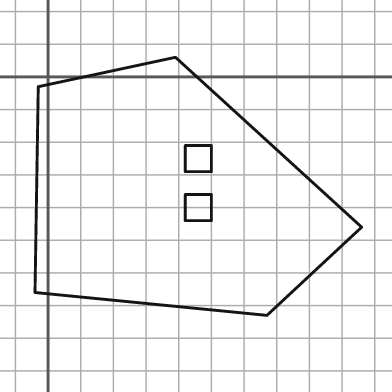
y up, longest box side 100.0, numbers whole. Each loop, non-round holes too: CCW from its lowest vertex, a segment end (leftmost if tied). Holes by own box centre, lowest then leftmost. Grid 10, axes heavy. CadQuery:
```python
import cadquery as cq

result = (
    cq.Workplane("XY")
    .moveTo(67.0, -73.0)
    .lineTo(96.0, -46.0)
    .lineTo(39.0, 6.0)
    .lineTo(-3.0, -3.0)
    .lineTo(-4.0, -66.0)
    .close()
    .moveTo(42.0, -44.0)
    .lineTo(50.0, -44.0)
    .lineTo(50.0, -36.0)
    .lineTo(42.0, -36.0)
    .close()
    .moveTo(42.0, -29.0)
    .lineTo(50.0, -29.0)
    .lineTo(50.0, -21.0)
    .lineTo(42.0, -21.0)
    .close()
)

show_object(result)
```